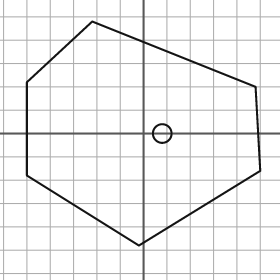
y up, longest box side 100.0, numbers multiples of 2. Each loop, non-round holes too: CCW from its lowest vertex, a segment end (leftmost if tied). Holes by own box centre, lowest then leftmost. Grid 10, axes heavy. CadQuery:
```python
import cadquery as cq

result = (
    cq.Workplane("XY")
    .moveTo(-2.0, -48.0)
    .lineTo(50.0, -16.0)
    .lineTo(48.0, 20.0)
    .lineTo(-22.0, 48.0)
    .lineTo(-50.0, 22.0)
    .lineTo(-50.0, -18.0)
    .close()
    .moveTo(8.0, 0.0)
    .circle(4.0)
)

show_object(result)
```